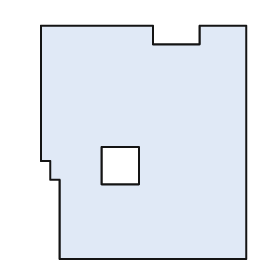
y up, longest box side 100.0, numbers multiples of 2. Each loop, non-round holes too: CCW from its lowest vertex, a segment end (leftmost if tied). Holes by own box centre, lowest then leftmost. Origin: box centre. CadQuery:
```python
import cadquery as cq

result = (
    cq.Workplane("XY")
    .moveTo(-36.0, -50.0)
    .lineTo(44.0, -50.0)
    .lineTo(44.0, 50.0)
    .lineTo(24.0, 50.0)
    .lineTo(24.0, 42.0)
    .lineTo(4.0, 42.0)
    .lineTo(4.0, 50.0)
    .lineTo(-44.0, 50.0)
    .lineTo(-44.0, -8.0)
    .lineTo(-40.0, -8.0)
    .lineTo(-40.0, -16.0)
    .lineTo(-36.0, -16.0)
    .close()
    .moveTo(-18.0, -18.0)
    .lineTo(-2.0, -18.0)
    .lineTo(-2.0, -2.0)
    .lineTo(-18.0, -2.0)
    .close()
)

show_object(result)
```